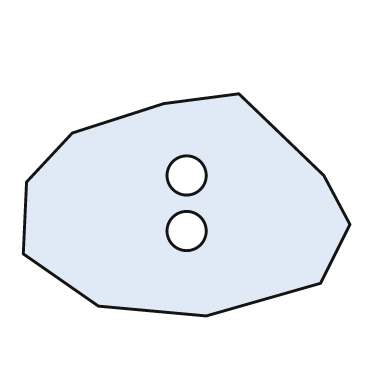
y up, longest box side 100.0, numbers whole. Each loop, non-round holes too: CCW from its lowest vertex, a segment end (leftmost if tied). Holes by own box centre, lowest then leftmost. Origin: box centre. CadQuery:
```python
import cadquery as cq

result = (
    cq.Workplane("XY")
    .moveTo(6.0, -34.0)
    .lineTo(41.0, -24.0)
    .lineTo(50.0, -6.0)
    .lineTo(42.0, 9.0)
    .lineTo(16.0, 34.0)
    .lineTo(-7.0, 31.0)
    .lineTo(-35.0, 22.0)
    .lineTo(-49.0, 7.0)
    .lineTo(-50.0, -15.0)
    .lineTo(-27.0, -31.0)
    .close()
    .moveTo(0.0, -8.0)
    .circle(6.0)
    .moveTo(0.0, 9.0)
    .circle(6.0)
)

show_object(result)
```